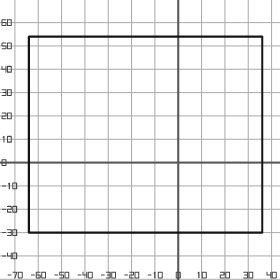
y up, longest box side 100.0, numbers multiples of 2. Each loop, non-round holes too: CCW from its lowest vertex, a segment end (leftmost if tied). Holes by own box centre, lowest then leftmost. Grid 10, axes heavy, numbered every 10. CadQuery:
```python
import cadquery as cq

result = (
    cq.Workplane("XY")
    .moveTo(-64.0, -30.0)
    .lineTo(36.0, -30.0)
    .lineTo(36.0, 54.0)
    .lineTo(-64.0, 54.0)
    .close()
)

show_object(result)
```